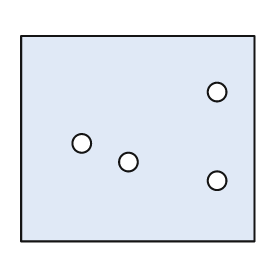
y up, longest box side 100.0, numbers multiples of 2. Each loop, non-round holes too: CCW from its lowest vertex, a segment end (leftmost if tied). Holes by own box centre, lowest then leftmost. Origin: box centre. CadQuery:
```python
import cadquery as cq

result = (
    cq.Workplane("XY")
    .moveTo(-50.0, -44.0)
    .lineTo(50.0, -44.0)
    .lineTo(50.0, 44.0)
    .lineTo(-50.0, 44.0)
    .close()
    .moveTo(34.0, -18.0)
    .circle(4.0)
    .moveTo(-4.0, -10.0)
    .circle(4.0)
    .moveTo(-24.0, -2.0)
    .circle(4.0)
    .moveTo(34.0, 20.0)
    .circle(4.0)
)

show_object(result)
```